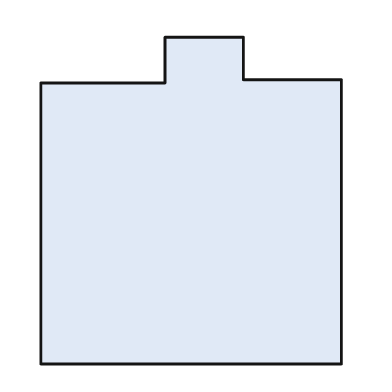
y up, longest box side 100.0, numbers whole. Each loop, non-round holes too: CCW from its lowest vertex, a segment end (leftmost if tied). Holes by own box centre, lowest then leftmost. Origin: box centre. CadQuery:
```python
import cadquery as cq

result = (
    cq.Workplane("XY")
    .moveTo(-46.0, -50.0)
    .lineTo(46.0, -50.0)
    .lineTo(46.0, 37.0)
    .lineTo(16.0, 37.0)
    .lineTo(16.0, 50.0)
    .lineTo(-8.0, 50.0)
    .lineTo(-8.0, 36.0)
    .lineTo(-46.0, 36.0)
    .close()
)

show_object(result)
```